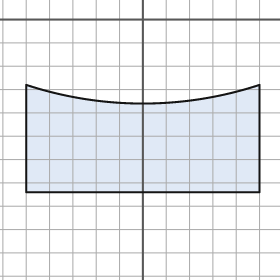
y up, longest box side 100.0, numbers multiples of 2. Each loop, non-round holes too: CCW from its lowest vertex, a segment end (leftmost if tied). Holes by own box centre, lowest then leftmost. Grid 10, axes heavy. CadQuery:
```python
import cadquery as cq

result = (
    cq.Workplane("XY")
    .moveTo(-50.0, -74.0)
    .lineTo(50.0, -74.0)
    .lineTo(50.0, -28.0)
    .threePointArc((0.0, -36.0), (-50.0, -28.0))
    .close()
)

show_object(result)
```